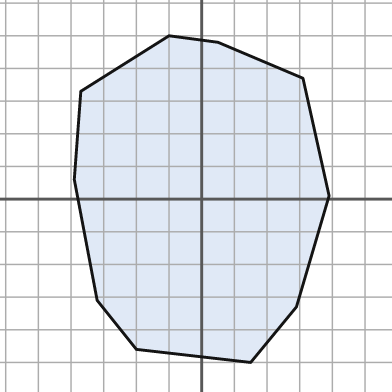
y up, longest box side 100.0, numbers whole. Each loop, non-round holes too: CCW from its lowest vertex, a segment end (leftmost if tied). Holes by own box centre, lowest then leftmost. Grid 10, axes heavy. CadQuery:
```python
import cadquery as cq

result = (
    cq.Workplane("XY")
    .moveTo(15.0, -50.0)
    .lineTo(29.0, -33.0)
    .lineTo(39.0, 1.0)
    .lineTo(31.0, 37.0)
    .lineTo(5.0, 48.0)
    .lineTo(-10.0, 50.0)
    .lineTo(-37.0, 33.0)
    .lineTo(-39.0, 6.0)
    .lineTo(-32.0, -31.0)
    .lineTo(-20.0, -46.0)
    .close()
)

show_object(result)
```